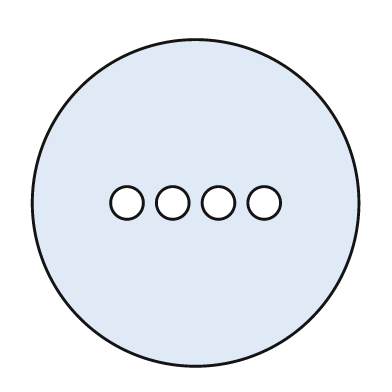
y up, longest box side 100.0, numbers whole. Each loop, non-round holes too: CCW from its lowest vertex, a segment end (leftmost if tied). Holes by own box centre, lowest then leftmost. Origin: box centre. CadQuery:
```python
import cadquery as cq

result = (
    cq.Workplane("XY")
    .moveTo(0.0, 0.0)
    .circle(50.0)
    .moveTo(-21.0, 0.0)
    .circle(5.0)
    .moveTo(-7.0, 0.0)
    .circle(5.0)
    .moveTo(7.0, 0.0)
    .circle(5.0)
    .moveTo(21.0, 0.0)
    .circle(5.0)
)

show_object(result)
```